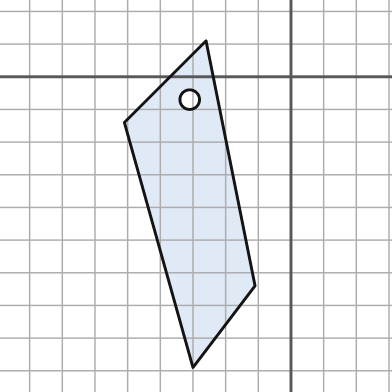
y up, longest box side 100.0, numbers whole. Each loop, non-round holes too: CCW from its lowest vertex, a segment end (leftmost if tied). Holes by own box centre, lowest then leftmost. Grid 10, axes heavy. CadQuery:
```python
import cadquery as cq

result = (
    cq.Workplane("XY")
    .moveTo(-30.0, -89.0)
    .lineTo(-11.0, -64.0)
    .lineTo(-26.0, 11.0)
    .lineTo(-51.0, -14.0)
    .close()
    .moveTo(-31.0, -7.0)
    .circle(3.0)
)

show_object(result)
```